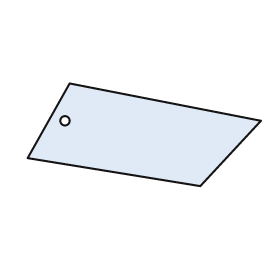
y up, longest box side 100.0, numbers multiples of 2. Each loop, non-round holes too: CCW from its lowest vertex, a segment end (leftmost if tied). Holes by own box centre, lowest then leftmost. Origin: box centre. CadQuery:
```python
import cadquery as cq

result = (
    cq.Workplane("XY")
    .moveTo(24.0, -22.0)
    .lineTo(50.0, 6.0)
    .lineTo(-32.0, 22.0)
    .lineTo(-50.0, -10.0)
    .close()
    .moveTo(-34.0, 6.0)
    .circle(2.0)
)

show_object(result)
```